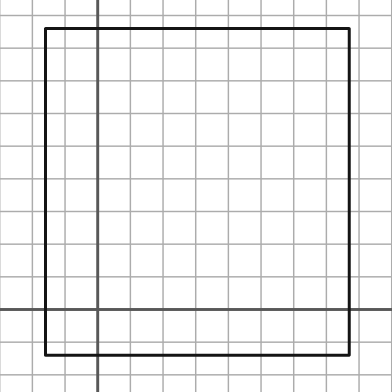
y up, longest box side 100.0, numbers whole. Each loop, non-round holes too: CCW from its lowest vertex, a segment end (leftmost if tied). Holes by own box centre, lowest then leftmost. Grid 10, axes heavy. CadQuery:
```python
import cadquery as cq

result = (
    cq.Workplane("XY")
    .moveTo(-16.0, -14.0)
    .lineTo(77.0, -14.0)
    .lineTo(77.0, 86.0)
    .lineTo(-16.0, 86.0)
    .close()
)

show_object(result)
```